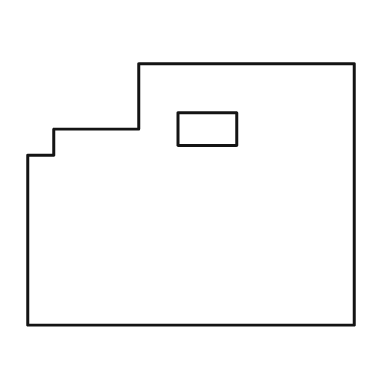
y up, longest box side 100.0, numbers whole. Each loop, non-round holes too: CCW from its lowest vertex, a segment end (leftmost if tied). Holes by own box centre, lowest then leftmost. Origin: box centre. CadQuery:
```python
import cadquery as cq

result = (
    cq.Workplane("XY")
    .moveTo(-50.0, -40.0)
    .lineTo(50.0, -40.0)
    .lineTo(50.0, 40.0)
    .lineTo(-16.0, 40.0)
    .lineTo(-16.0, 20.0)
    .lineTo(-42.0, 20.0)
    .lineTo(-42.0, 12.0)
    .lineTo(-50.0, 12.0)
    .close()
    .moveTo(-4.0, 15.0)
    .lineTo(14.0, 15.0)
    .lineTo(14.0, 25.0)
    .lineTo(-4.0, 25.0)
    .close()
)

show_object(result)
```